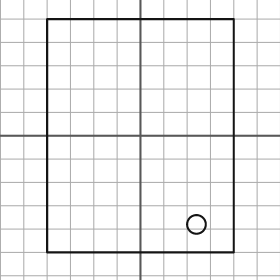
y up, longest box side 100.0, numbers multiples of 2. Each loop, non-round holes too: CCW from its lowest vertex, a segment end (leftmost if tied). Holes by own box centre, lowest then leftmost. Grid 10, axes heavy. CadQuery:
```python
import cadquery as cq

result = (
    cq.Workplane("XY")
    .moveTo(-40.0, -50.0)
    .lineTo(40.0, -50.0)
    .lineTo(40.0, 50.0)
    .lineTo(-40.0, 50.0)
    .close()
    .moveTo(24.0, -38.0)
    .circle(4.0)
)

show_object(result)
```